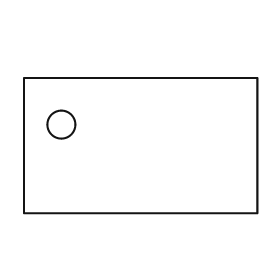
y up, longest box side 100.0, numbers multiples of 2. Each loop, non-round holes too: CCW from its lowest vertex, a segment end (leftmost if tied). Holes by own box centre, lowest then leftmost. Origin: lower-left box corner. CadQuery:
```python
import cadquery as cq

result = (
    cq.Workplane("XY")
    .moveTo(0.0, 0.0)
    .lineTo(100.0, 0.0)
    .lineTo(100.0, 58.0)
    .lineTo(0.0, 58.0)
    .close()
    .moveTo(16.0, 38.0)
    .circle(6.0)
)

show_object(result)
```